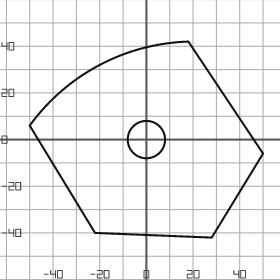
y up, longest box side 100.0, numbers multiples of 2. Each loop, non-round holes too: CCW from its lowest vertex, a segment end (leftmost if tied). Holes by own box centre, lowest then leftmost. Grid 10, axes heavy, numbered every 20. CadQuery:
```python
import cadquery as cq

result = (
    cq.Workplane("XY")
    .moveTo(28.0, -42.0)
    .lineTo(50.0, -6.0)
    .lineTo(18.0, 42.0)
    .threePointArc((-20.0, 32.0), (-50.0, 6.0))
    .lineTo(-22.0, -40.0)
    .close()
    .moveTo(0.0, 0.0)
    .circle(8.0)
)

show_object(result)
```